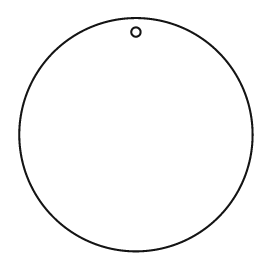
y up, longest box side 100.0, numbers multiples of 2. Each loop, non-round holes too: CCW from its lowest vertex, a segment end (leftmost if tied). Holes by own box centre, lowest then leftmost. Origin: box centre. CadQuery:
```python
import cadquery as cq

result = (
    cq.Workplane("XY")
    .moveTo(0.0, 0.0)
    .circle(50.0)
    .moveTo(0.0, 44.0)
    .circle(2.0)
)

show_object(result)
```